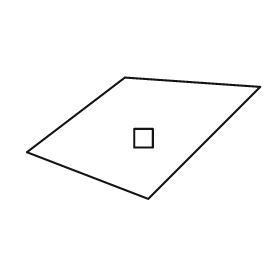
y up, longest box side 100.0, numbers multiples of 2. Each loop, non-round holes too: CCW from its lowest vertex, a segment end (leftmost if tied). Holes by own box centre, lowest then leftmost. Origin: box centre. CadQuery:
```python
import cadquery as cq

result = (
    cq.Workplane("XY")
    .moveTo(2.0, -26.0)
    .lineTo(50.0, 22.0)
    .lineTo(-8.0, 26.0)
    .lineTo(-50.0, -6.0)
    .close()
    .moveTo(-4.0, -4.0)
    .lineTo(4.0, -4.0)
    .lineTo(4.0, 4.0)
    .lineTo(-4.0, 4.0)
    .close()
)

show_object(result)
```